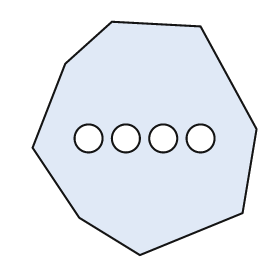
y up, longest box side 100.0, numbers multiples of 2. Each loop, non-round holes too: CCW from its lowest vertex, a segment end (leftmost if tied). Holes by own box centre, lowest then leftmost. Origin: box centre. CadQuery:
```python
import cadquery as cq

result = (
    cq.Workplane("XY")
    .moveTo(-2.0, -50.0)
    .lineTo(42.0, -32.0)
    .lineTo(48.0, 4.0)
    .lineTo(24.0, 48.0)
    .lineTo(-14.0, 50.0)
    .lineTo(-34.0, 32.0)
    .lineTo(-48.0, -4.0)
    .lineTo(-28.0, -34.0)
    .close()
    .moveTo(-24.0, 0.0)
    .circle(6.0)
    .moveTo(-8.0, 0.0)
    .circle(6.0)
    .moveTo(8.0, 0.0)
    .circle(6.0)
    .moveTo(24.0, 0.0)
    .circle(6.0)
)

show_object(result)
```